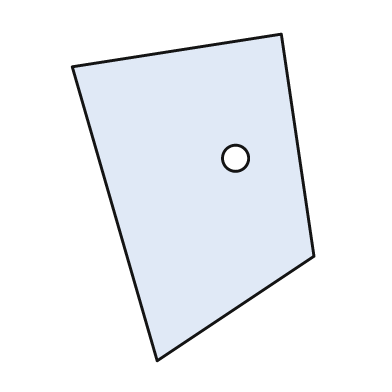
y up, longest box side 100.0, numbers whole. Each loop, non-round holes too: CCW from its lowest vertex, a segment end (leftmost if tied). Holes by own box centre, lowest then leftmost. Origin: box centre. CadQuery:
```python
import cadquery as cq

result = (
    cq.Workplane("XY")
    .moveTo(-11.0, -50.0)
    .lineTo(37.0, -18.0)
    .lineTo(27.0, 50.0)
    .lineTo(-37.0, 40.0)
    .close()
    .moveTo(13.0, 12.0)
    .circle(4.0)
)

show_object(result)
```